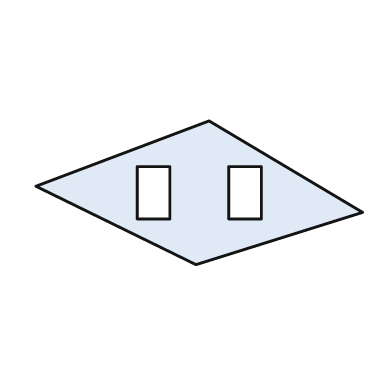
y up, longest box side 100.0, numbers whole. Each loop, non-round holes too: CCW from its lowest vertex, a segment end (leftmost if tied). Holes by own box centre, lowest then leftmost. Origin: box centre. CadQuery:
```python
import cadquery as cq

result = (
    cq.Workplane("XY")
    .moveTo(-1.0, -22.0)
    .lineTo(50.0, -6.0)
    .lineTo(3.0, 22.0)
    .lineTo(-50.0, 2.0)
    .close()
    .moveTo(-19.0, -8.0)
    .lineTo(-9.0, -8.0)
    .lineTo(-9.0, 8.0)
    .lineTo(-19.0, 8.0)
    .close()
    .moveTo(9.0, -8.0)
    .lineTo(19.0, -8.0)
    .lineTo(19.0, 8.0)
    .lineTo(9.0, 8.0)
    .close()
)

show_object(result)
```